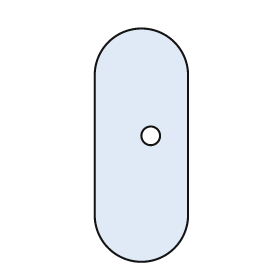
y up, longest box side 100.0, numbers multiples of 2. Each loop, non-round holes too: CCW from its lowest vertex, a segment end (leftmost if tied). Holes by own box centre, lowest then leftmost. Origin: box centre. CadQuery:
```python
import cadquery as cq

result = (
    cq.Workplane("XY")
    .moveTo(-20.0, -30.0)
    .threePointArc((0.0, -50.0), (20.0, -30.0))
    .lineTo(20.0, 30.0)
    .threePointArc((0.0, 50.0), (-20.0, 30.0))
    .close()
    .moveTo(4.0, 4.0)
    .circle(4.0)
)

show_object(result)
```